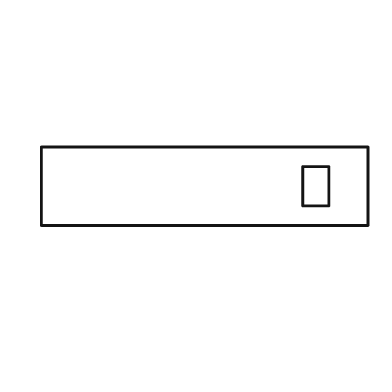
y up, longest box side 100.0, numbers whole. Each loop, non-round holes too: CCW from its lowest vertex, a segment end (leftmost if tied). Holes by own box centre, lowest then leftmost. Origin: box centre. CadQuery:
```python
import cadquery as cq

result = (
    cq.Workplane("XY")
    .moveTo(-50.0, -12.0)
    .lineTo(50.0, -12.0)
    .lineTo(50.0, 12.0)
    .lineTo(-50.0, 12.0)
    .close()
    .moveTo(30.0, -6.0)
    .lineTo(38.0, -6.0)
    .lineTo(38.0, 6.0)
    .lineTo(30.0, 6.0)
    .close()
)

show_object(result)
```